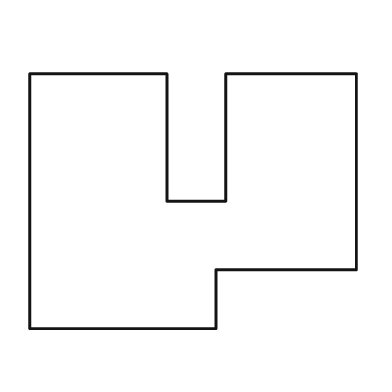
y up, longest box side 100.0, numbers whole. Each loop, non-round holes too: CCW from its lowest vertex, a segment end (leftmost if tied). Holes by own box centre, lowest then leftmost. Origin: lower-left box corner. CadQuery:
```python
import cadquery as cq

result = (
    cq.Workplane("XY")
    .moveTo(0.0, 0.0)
    .lineTo(57.0, 0.0)
    .lineTo(57.0, 18.0)
    .lineTo(100.0, 18.0)
    .lineTo(100.0, 78.0)
    .lineTo(60.0, 78.0)
    .lineTo(60.0, 39.0)
    .lineTo(42.0, 39.0)
    .lineTo(42.0, 78.0)
    .lineTo(0.0, 78.0)
    .close()
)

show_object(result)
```